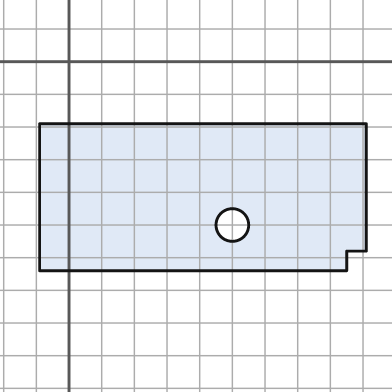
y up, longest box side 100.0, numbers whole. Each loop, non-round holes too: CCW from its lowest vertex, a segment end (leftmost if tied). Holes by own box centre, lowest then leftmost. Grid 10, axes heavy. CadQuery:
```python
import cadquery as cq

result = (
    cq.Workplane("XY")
    .moveTo(-9.0, -64.0)
    .lineTo(85.0, -64.0)
    .lineTo(85.0, -58.0)
    .lineTo(91.0, -58.0)
    .lineTo(91.0, -19.0)
    .lineTo(-9.0, -19.0)
    .close()
    .moveTo(50.0, -50.0)
    .circle(5.0)
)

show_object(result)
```